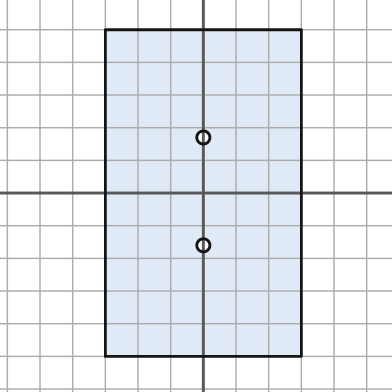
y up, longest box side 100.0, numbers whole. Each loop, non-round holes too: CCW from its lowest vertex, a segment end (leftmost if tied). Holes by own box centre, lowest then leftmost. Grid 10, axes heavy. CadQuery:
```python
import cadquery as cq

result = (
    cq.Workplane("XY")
    .moveTo(-30.0, -50.0)
    .lineTo(30.0, -50.0)
    .lineTo(30.0, 50.0)
    .lineTo(-30.0, 50.0)
    .close()
    .moveTo(0.0, -16.0)
    .circle(2.0)
    .moveTo(0.0, 17.0)
    .circle(2.0)
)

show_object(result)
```